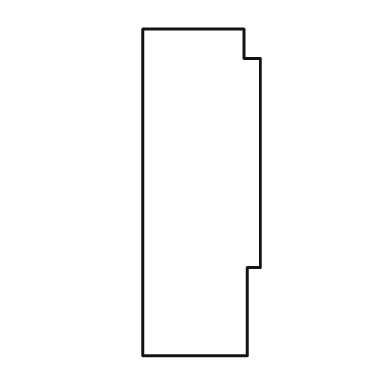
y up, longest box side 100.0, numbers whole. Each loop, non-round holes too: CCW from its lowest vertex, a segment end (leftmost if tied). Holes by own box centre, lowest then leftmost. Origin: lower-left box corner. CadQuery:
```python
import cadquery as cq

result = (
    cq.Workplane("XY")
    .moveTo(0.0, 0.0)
    .lineTo(32.0, 0.0)
    .lineTo(32.0, 27.0)
    .lineTo(36.0, 27.0)
    .lineTo(36.0, 91.0)
    .lineTo(31.0, 91.0)
    .lineTo(31.0, 100.0)
    .lineTo(0.0, 100.0)
    .close()
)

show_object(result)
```